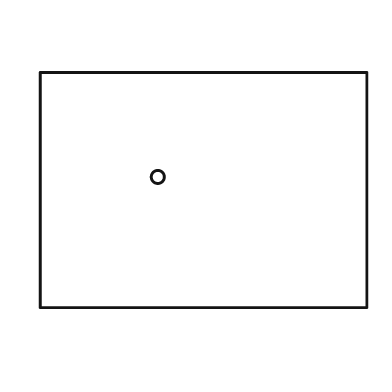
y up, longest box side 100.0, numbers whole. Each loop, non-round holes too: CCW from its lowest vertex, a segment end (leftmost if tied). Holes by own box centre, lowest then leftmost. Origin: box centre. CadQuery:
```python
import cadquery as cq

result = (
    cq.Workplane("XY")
    .moveTo(-50.0, -36.0)
    .lineTo(50.0, -36.0)
    .lineTo(50.0, 36.0)
    .lineTo(-50.0, 36.0)
    .close()
    .moveTo(-14.0, 4.0)
    .circle(2.0)
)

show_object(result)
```